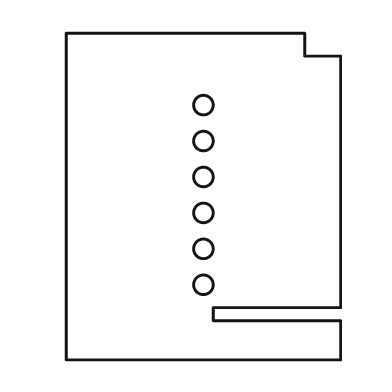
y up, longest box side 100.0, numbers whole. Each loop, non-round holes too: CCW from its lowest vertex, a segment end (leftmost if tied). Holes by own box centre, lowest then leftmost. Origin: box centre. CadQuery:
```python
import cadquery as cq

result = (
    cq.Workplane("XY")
    .moveTo(-42.0, -50.0)
    .lineTo(42.0, -50.0)
    .lineTo(42.0, -38.0)
    .lineTo(3.0, -38.0)
    .lineTo(3.0, -34.0)
    .lineTo(42.0, -34.0)
    .lineTo(42.0, 43.0)
    .lineTo(31.0, 43.0)
    .lineTo(31.0, 50.0)
    .lineTo(-42.0, 50.0)
    .close()
    .moveTo(0.0, -27.0)
    .circle(3.0)
    .moveTo(0.0, -16.0)
    .circle(3.0)
    .moveTo(0.0, -5.0)
    .circle(3.0)
    .moveTo(0.0, 6.0)
    .circle(3.0)
    .moveTo(0.0, 17.0)
    .circle(3.0)
    .moveTo(0.0, 28.0)
    .circle(3.0)
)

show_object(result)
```